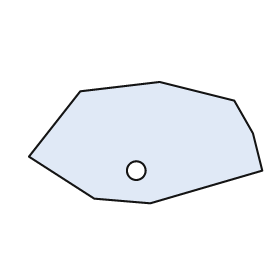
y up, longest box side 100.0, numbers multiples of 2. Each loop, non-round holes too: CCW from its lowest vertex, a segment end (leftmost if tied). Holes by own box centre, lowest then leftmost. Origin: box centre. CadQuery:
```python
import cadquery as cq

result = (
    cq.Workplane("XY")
    .moveTo(2.0, -26.0)
    .lineTo(50.0, -12.0)
    .lineTo(46.0, 4.0)
    .lineTo(38.0, 18.0)
    .lineTo(6.0, 26.0)
    .lineTo(-28.0, 22.0)
    .lineTo(-50.0, -6.0)
    .lineTo(-22.0, -24.0)
    .close()
    .moveTo(-4.0, -12.0)
    .circle(4.0)
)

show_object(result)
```